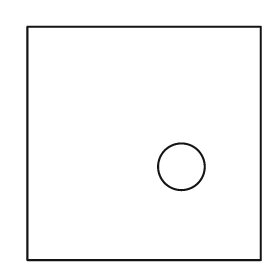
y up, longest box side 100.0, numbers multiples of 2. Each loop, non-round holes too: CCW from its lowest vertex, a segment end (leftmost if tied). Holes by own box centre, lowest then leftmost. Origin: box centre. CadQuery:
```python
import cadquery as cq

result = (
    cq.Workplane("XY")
    .moveTo(-50.0, -50.0)
    .lineTo(50.0, -50.0)
    .lineTo(50.0, 50.0)
    .lineTo(-50.0, 50.0)
    .close()
    .moveTo(16.0, -10.0)
    .circle(10.0)
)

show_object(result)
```